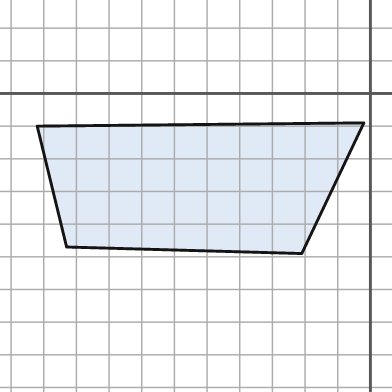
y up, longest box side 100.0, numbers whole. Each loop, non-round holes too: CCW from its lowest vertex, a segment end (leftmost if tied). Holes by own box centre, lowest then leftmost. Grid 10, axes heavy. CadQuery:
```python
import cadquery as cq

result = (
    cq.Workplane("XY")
    .moveTo(-21.0, -49.0)
    .lineTo(-2.0, -9.0)
    .lineTo(-102.0, -10.0)
    .lineTo(-93.0, -47.0)
    .close()
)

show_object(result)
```